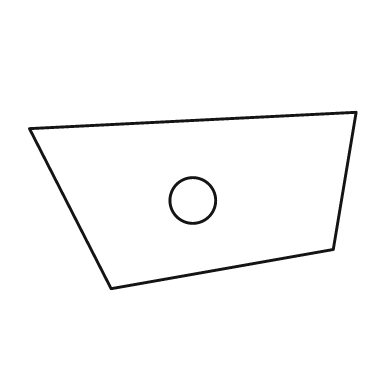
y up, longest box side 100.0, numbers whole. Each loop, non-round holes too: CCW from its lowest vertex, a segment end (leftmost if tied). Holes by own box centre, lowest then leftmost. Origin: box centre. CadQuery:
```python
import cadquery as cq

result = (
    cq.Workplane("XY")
    .moveTo(-25.0, -27.0)
    .lineTo(43.0, -15.0)
    .lineTo(50.0, 27.0)
    .lineTo(-50.0, 22.0)
    .close()
    .moveTo(0.0, 0.0)
    .circle(7.0)
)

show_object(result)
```